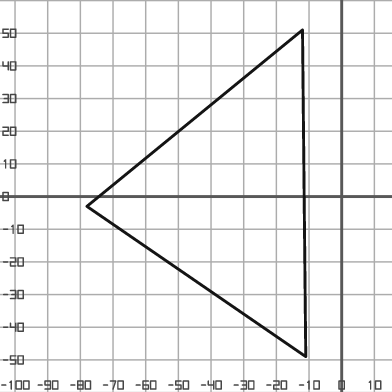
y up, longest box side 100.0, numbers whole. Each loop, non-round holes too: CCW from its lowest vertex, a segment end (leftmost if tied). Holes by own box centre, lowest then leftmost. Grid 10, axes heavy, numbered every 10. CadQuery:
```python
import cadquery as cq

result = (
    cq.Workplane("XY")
    .moveTo(-11.0, -49.0)
    .lineTo(-12.0, 51.0)
    .lineTo(-78.0, -3.0)
    .close()
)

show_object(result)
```